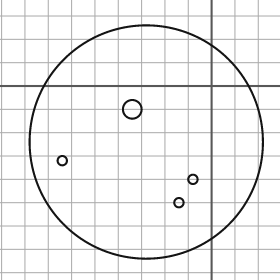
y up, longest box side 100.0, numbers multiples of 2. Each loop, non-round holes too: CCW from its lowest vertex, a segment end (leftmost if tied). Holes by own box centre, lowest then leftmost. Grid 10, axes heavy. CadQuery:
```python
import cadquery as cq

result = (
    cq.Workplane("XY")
    .moveTo(-28.0, -24.0)
    .circle(50.0)
    .moveTo(-14.0, -50.0)
    .circle(2.0)
    .moveTo(-8.0, -40.0)
    .circle(2.0)
    .moveTo(-64.0, -32.0)
    .circle(2.0)
    .moveTo(-34.0, -10.0)
    .circle(4.0)
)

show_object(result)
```